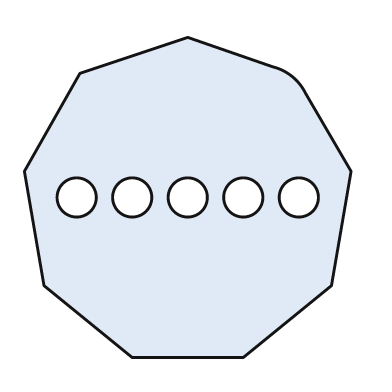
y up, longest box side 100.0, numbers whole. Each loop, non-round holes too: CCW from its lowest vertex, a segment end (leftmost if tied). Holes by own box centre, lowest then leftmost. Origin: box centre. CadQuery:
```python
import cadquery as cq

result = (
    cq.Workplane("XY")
    .moveTo(-17.0, -49.0)
    .lineTo(17.0, -49.0)
    .lineTo(44.0, -27.0)
    .lineTo(50.0, 8.0)
    .lineTo(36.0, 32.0)
    .threePointArc((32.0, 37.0), (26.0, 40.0))
    .lineTo(0.0, 49.0)
    .lineTo(-33.0, 38.0)
    .lineTo(-50.0, 8.0)
    .lineTo(-44.0, -27.0)
    .close()
    .moveTo(-34.0, 0.0)
    .circle(6.0)
    .moveTo(-17.0, 0.0)
    .circle(6.0)
    .moveTo(0.0, 0.0)
    .circle(6.0)
    .moveTo(17.0, 0.0)
    .circle(6.0)
    .moveTo(34.0, 0.0)
    .circle(6.0)
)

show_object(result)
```